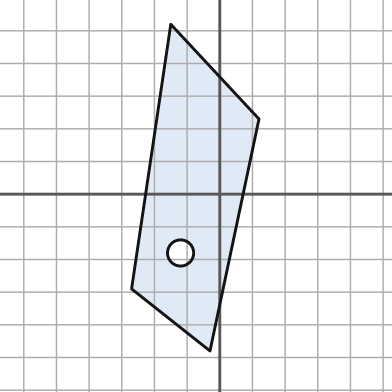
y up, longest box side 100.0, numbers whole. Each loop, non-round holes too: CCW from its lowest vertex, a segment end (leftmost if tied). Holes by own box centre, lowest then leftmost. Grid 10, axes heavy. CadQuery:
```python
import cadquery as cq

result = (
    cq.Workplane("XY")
    .moveTo(-3.0, -48.0)
    .lineTo(12.0, 23.0)
    .lineTo(-15.0, 52.0)
    .lineTo(-27.0, -29.0)
    .close()
    .moveTo(-12.0, -18.0)
    .circle(4.0)
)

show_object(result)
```